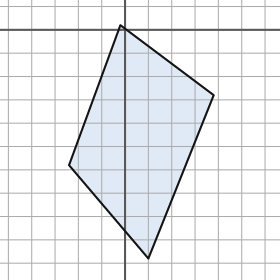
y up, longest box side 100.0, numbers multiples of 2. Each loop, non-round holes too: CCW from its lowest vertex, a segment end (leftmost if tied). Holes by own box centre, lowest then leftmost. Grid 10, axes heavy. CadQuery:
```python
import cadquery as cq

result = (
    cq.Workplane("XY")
    .moveTo(10.0, -98.0)
    .lineTo(38.0, -28.0)
    .lineTo(-2.0, 2.0)
    .lineTo(-24.0, -58.0)
    .close()
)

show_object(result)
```